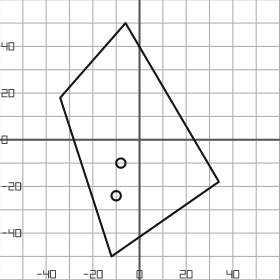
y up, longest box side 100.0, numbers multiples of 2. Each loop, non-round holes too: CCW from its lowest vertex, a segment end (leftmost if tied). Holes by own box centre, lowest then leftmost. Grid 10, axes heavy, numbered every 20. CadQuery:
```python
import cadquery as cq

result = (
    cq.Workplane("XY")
    .moveTo(-12.0, -50.0)
    .lineTo(34.0, -18.0)
    .lineTo(-6.0, 50.0)
    .lineTo(-34.0, 18.0)
    .close()
    .moveTo(-10.0, -24.0)
    .circle(2.0)
    .moveTo(-8.0, -10.0)
    .circle(2.0)
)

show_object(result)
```